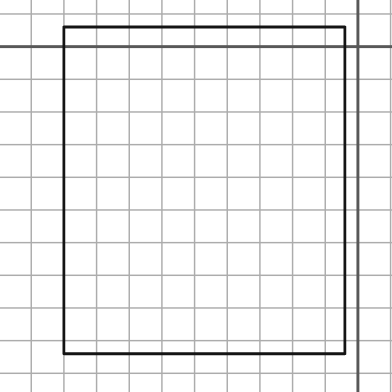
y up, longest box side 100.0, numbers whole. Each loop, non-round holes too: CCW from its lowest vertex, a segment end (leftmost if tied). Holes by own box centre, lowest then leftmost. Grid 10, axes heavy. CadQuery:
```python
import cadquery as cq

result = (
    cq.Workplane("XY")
    .moveTo(-90.0, -94.0)
    .lineTo(-4.0, -94.0)
    .lineTo(-4.0, 6.0)
    .lineTo(-90.0, 6.0)
    .close()
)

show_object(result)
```